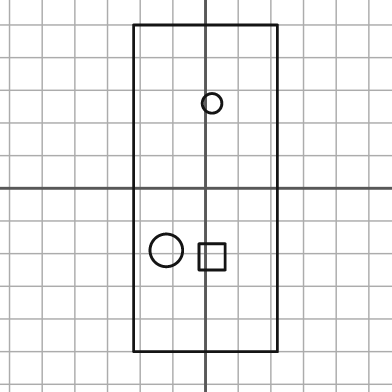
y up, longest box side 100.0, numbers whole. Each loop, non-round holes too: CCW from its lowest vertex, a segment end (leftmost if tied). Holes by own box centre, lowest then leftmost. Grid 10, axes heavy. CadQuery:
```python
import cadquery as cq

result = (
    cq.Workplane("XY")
    .moveTo(-22.0, -50.0)
    .lineTo(22.0, -50.0)
    .lineTo(22.0, 50.0)
    .lineTo(-22.0, 50.0)
    .close()
    .moveTo(-2.0, -25.0)
    .lineTo(6.0, -25.0)
    .lineTo(6.0, -17.0)
    .lineTo(-2.0, -17.0)
    .close()
    .moveTo(-12.0, -19.0)
    .circle(5.0)
    .moveTo(2.0, 26.0)
    .circle(3.0)
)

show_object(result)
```